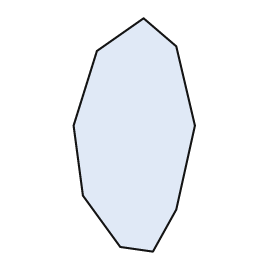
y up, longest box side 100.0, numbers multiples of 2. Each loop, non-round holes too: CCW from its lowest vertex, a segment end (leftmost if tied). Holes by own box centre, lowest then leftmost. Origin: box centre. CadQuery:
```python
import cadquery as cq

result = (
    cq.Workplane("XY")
    .moveTo(8.0, -50.0)
    .lineTo(18.0, -32.0)
    .lineTo(26.0, 4.0)
    .lineTo(18.0, 38.0)
    .lineTo(4.0, 50.0)
    .lineTo(-16.0, 36.0)
    .lineTo(-26.0, 4.0)
    .lineTo(-22.0, -26.0)
    .lineTo(-6.0, -48.0)
    .close()
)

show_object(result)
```